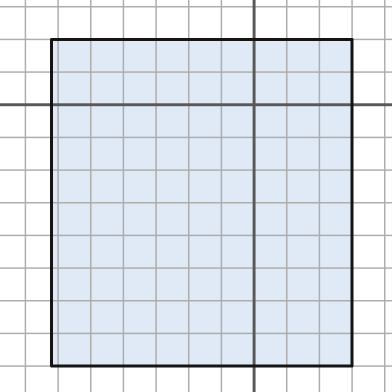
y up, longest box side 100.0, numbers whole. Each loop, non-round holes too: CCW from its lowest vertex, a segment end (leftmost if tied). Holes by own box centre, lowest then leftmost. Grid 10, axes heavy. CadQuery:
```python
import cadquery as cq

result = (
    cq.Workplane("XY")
    .moveTo(-62.0, -80.0)
    .lineTo(30.0, -80.0)
    .lineTo(30.0, 20.0)
    .lineTo(-62.0, 20.0)
    .close()
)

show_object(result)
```